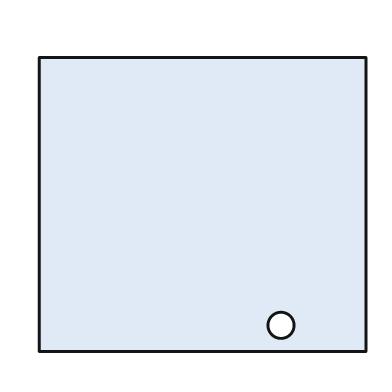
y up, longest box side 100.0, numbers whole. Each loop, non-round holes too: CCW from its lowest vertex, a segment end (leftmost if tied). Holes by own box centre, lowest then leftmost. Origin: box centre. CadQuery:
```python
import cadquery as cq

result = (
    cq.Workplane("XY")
    .moveTo(-50.0, -45.0)
    .lineTo(50.0, -45.0)
    .lineTo(50.0, 45.0)
    .lineTo(-50.0, 45.0)
    .close()
    .moveTo(24.0, -37.0)
    .circle(4.0)
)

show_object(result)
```